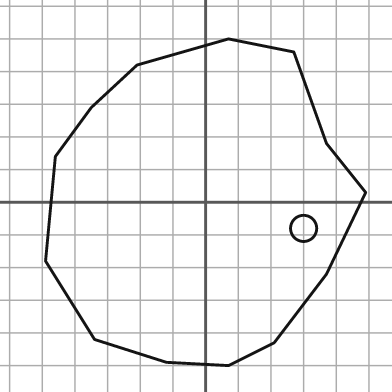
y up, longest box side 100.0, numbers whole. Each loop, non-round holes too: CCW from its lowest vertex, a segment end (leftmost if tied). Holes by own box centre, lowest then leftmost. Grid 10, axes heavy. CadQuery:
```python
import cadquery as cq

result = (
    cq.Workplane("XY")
    .moveTo(7.0, -50.0)
    .lineTo(21.0, -43.0)
    .lineTo(37.0, -22.0)
    .lineTo(49.0, 3.0)
    .lineTo(37.0, 18.0)
    .lineTo(27.0, 46.0)
    .lineTo(7.0, 50.0)
    .lineTo(-21.0, 42.0)
    .lineTo(-35.0, 29.0)
    .lineTo(-46.0, 14.0)
    .lineTo(-49.0, -18.0)
    .lineTo(-34.0, -42.0)
    .lineTo(-12.0, -49.0)
    .close()
    .moveTo(30.0, -8.0)
    .circle(4.0)
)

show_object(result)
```